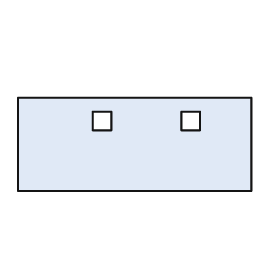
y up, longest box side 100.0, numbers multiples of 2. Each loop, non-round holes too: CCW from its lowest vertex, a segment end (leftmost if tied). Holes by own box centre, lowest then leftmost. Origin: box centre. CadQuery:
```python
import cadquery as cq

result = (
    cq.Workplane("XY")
    .moveTo(-50.0, -20.0)
    .lineTo(50.0, -20.0)
    .lineTo(50.0, 20.0)
    .lineTo(-50.0, 20.0)
    .close()
    .moveTo(-18.0, 6.0)
    .lineTo(-10.0, 6.0)
    .lineTo(-10.0, 14.0)
    .lineTo(-18.0, 14.0)
    .close()
    .moveTo(20.0, 6.0)
    .lineTo(28.0, 6.0)
    .lineTo(28.0, 14.0)
    .lineTo(20.0, 14.0)
    .close()
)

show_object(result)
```